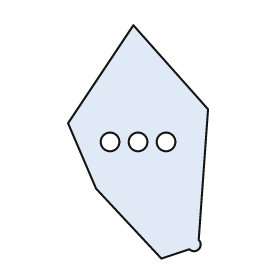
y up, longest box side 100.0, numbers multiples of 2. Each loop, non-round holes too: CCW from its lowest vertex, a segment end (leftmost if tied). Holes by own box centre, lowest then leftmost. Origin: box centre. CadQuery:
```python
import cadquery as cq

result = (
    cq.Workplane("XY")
    .moveTo(10.0, -50.0)
    .lineTo(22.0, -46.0)
    .threePointArc((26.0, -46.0), (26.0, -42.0))
    .lineTo(30.0, 14.0)
    .lineTo(-2.0, 50.0)
    .lineTo(-30.0, 8.0)
    .lineTo(-18.0, -20.0)
    .close()
    .moveTo(-12.0, 0.0)
    .circle(4.0)
    .moveTo(0.0, 0.0)
    .circle(4.0)
    .moveTo(12.0, 0.0)
    .circle(4.0)
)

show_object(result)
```